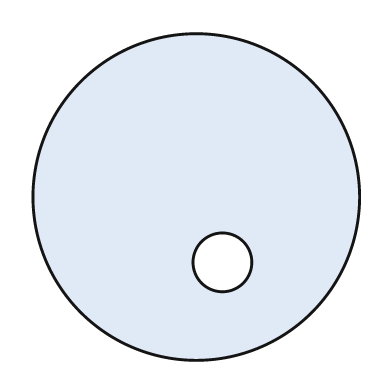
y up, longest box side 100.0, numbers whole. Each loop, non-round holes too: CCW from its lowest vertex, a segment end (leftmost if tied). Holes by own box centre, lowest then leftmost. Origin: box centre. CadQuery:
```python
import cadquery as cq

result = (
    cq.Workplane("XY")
    .moveTo(0.0, 0.0)
    .circle(50.0)
    .moveTo(8.0, -20.0)
    .circle(9.0)
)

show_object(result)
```